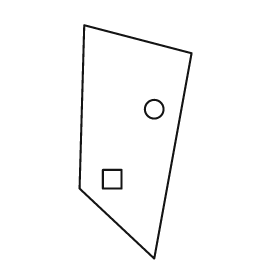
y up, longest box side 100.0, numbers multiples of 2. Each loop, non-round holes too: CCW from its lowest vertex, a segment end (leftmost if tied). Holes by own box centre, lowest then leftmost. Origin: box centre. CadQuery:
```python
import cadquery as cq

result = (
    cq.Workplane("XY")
    .moveTo(8.0, -50.0)
    .lineTo(24.0, 38.0)
    .lineTo(-22.0, 50.0)
    .lineTo(-24.0, -20.0)
    .close()
    .moveTo(-14.0, -20.0)
    .lineTo(-6.0, -20.0)
    .lineTo(-6.0, -12.0)
    .lineTo(-14.0, -12.0)
    .close()
    .moveTo(8.0, 14.0)
    .circle(4.0)
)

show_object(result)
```